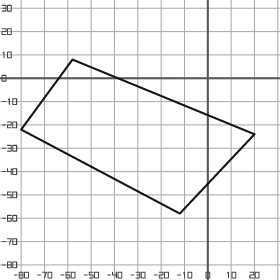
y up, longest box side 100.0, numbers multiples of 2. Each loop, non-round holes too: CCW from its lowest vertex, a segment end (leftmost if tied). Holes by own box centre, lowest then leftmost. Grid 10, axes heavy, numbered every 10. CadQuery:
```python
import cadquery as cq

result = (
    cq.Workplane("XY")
    .moveTo(-12.0, -58.0)
    .lineTo(20.0, -24.0)
    .lineTo(-58.0, 8.0)
    .lineTo(-80.0, -22.0)
    .close()
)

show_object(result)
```